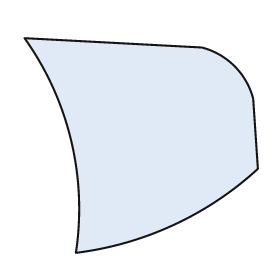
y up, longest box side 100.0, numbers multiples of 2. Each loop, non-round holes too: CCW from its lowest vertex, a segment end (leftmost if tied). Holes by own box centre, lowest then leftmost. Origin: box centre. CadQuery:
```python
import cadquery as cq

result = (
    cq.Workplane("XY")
    .moveTo(-28.0, -46.0)
    .threePointArc((14.0, -34.0), (50.0, -10.0))
    .lineTo(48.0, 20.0)
    .threePointArc((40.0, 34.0), (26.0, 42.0))
    .lineTo(-50.0, 46.0)
    .threePointArc((-30.0, 2.0), (-28.0, -46.0))
    .close()
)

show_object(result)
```